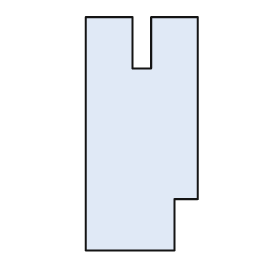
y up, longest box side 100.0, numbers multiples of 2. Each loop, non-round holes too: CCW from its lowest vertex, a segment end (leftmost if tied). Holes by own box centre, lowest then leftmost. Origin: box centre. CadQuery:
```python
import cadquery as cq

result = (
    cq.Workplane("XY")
    .moveTo(-24.0, -50.0)
    .lineTo(14.0, -50.0)
    .lineTo(14.0, -28.0)
    .lineTo(24.0, -28.0)
    .lineTo(24.0, 50.0)
    .lineTo(4.0, 50.0)
    .lineTo(4.0, 28.0)
    .lineTo(-4.0, 28.0)
    .lineTo(-4.0, 50.0)
    .lineTo(-24.0, 50.0)
    .close()
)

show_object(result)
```